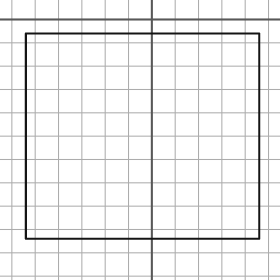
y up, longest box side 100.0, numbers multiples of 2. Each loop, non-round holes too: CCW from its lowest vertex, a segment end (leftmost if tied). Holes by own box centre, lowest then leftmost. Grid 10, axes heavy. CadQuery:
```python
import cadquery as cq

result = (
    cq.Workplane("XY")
    .moveTo(-54.0, -94.0)
    .lineTo(46.0, -94.0)
    .lineTo(46.0, -6.0)
    .lineTo(-54.0, -6.0)
    .close()
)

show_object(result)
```